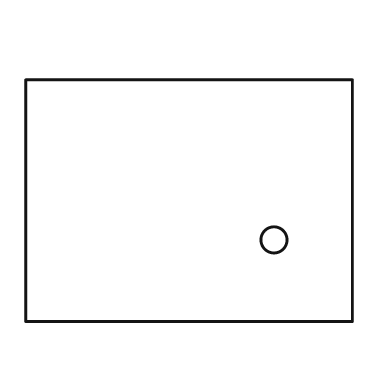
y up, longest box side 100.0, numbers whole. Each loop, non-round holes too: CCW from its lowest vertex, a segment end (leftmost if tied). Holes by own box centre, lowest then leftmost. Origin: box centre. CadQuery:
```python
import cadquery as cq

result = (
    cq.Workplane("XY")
    .moveTo(-50.0, -37.0)
    .lineTo(50.0, -37.0)
    .lineTo(50.0, 37.0)
    .lineTo(-50.0, 37.0)
    .close()
    .moveTo(26.0, -12.0)
    .circle(4.0)
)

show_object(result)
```